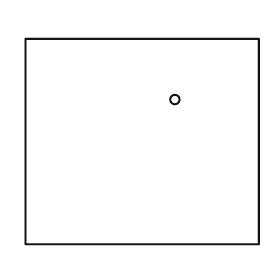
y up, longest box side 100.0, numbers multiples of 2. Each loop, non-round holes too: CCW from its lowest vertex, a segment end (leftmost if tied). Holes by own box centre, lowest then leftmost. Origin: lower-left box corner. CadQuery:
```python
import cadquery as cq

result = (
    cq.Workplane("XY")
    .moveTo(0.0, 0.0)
    .lineTo(100.0, 0.0)
    .lineTo(100.0, 88.0)
    .lineTo(0.0, 88.0)
    .close()
    .moveTo(64.0, 62.0)
    .circle(2.0)
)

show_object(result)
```